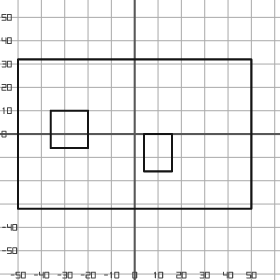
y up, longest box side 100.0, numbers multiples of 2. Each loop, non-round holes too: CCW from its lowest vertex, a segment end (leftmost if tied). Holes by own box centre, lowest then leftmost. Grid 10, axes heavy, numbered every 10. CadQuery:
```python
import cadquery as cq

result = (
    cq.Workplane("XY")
    .moveTo(-50.0, -32.0)
    .lineTo(50.0, -32.0)
    .lineTo(50.0, 32.0)
    .lineTo(-50.0, 32.0)
    .close()
    .moveTo(4.0, -16.0)
    .lineTo(16.0, -16.0)
    .lineTo(16.0, 0.0)
    .lineTo(4.0, 0.0)
    .close()
    .moveTo(-36.0, -6.0)
    .lineTo(-20.0, -6.0)
    .lineTo(-20.0, 10.0)
    .lineTo(-36.0, 10.0)
    .close()
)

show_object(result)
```